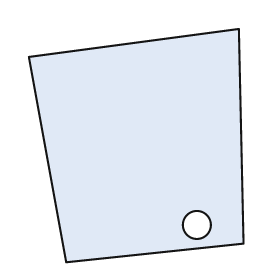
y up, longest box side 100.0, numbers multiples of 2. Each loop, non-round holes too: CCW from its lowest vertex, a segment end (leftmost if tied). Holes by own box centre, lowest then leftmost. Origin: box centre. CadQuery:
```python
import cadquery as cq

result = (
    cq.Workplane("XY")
    .moveTo(-30.0, -50.0)
    .lineTo(46.0, -42.0)
    .lineTo(44.0, 50.0)
    .lineTo(-46.0, 38.0)
    .close()
    .moveTo(26.0, -34.0)
    .circle(6.0)
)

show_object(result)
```